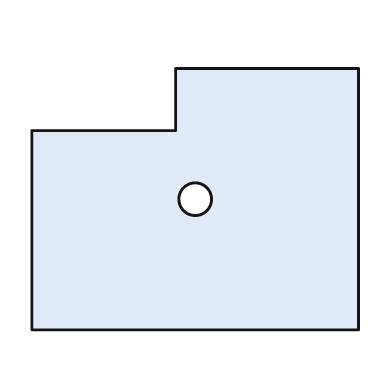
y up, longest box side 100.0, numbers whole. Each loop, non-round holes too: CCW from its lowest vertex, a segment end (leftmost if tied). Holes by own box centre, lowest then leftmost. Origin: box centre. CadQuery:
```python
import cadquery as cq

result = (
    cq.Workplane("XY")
    .moveTo(-50.0, -40.0)
    .lineTo(50.0, -40.0)
    .lineTo(50.0, 40.0)
    .lineTo(-6.0, 40.0)
    .lineTo(-6.0, 21.0)
    .lineTo(-50.0, 21.0)
    .close()
    .moveTo(0.0, 0.0)
    .circle(5.0)
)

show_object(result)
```